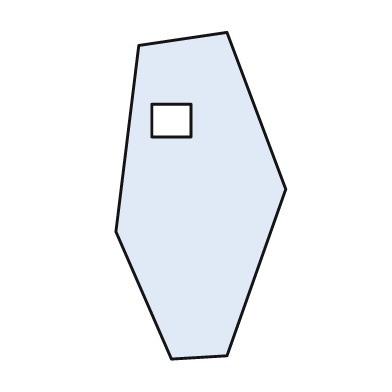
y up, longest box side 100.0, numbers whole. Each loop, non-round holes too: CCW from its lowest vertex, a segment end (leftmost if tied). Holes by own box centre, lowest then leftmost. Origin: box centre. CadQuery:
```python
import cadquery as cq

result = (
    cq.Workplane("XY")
    .moveTo(-9.0, -50.0)
    .lineTo(8.0, -49.0)
    .lineTo(26.0, 2.0)
    .lineTo(8.0, 50.0)
    .lineTo(-19.0, 46.0)
    .lineTo(-26.0, -11.0)
    .close()
    .moveTo(-15.0, 18.0)
    .lineTo(-3.0, 18.0)
    .lineTo(-3.0, 28.0)
    .lineTo(-15.0, 28.0)
    .close()
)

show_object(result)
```